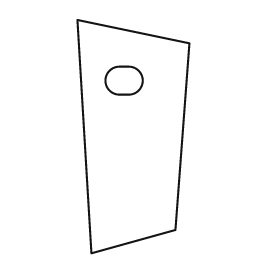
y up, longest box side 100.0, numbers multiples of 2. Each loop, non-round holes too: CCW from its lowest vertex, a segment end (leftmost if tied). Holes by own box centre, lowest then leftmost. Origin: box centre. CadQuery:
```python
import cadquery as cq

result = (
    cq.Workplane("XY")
    .moveTo(-18.0, -50.0)
    .lineTo(18.0, -40.0)
    .lineTo(24.0, 40.0)
    .lineTo(-24.0, 50.0)
    .close()
    .moveTo(-6.0, 18.0)
    .lineTo(-2.0, 18.0)
    .threePointArc((4.0, 24.0), (-2.0, 30.0))
    .lineTo(-6.0, 30.0)
    .threePointArc((-12.0, 24.0), (-6.0, 18.0))
    .close()
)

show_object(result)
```